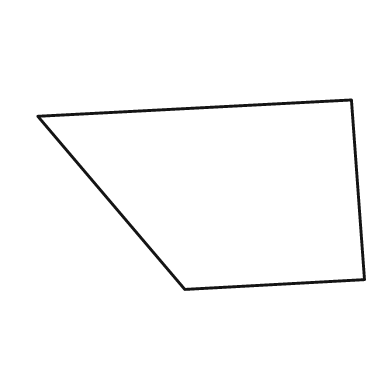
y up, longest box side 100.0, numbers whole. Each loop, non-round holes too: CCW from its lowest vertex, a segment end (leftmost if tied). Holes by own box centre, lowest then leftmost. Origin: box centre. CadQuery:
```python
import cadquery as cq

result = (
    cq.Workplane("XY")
    .moveTo(-5.0, -29.0)
    .lineTo(50.0, -26.0)
    .lineTo(46.0, 29.0)
    .lineTo(-50.0, 24.0)
    .close()
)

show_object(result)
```